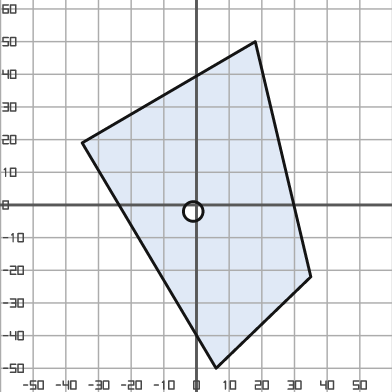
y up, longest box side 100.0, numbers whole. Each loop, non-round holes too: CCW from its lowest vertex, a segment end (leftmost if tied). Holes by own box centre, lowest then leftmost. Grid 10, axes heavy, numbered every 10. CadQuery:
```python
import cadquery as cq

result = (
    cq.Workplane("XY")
    .moveTo(6.0, -50.0)
    .lineTo(35.0, -22.0)
    .lineTo(18.0, 50.0)
    .lineTo(-35.0, 19.0)
    .close()
    .moveTo(-1.0, -2.0)
    .circle(3.0)
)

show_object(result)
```